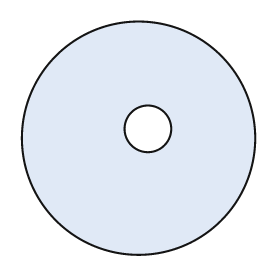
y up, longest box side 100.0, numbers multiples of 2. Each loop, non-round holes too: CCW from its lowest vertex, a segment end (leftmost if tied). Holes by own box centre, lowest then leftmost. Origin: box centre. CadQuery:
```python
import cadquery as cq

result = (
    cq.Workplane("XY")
    .moveTo(0.0, 0.0)
    .circle(50.0)
    .moveTo(4.0, 4.0)
    .circle(10.0)
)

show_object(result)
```